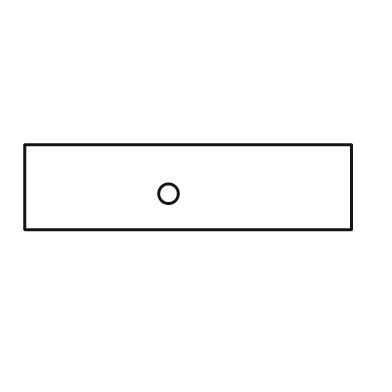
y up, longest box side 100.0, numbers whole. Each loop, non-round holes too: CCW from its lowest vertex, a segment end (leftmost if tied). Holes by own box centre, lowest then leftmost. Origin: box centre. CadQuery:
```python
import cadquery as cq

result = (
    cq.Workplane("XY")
    .moveTo(-50.0, -13.0)
    .lineTo(50.0, -13.0)
    .lineTo(50.0, 13.0)
    .lineTo(-50.0, 13.0)
    .close()
    .moveTo(-6.0, -2.0)
    .circle(3.0)
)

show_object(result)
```